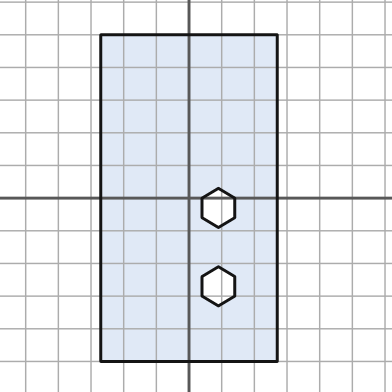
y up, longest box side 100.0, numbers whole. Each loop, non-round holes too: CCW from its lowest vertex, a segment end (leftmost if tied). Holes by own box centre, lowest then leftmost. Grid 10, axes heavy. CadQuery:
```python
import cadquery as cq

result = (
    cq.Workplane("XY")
    .moveTo(-27.0, -50.0)
    .lineTo(27.0, -50.0)
    .lineTo(27.0, 50.0)
    .lineTo(-27.0, 50.0)
    .close()
    .moveTo(9.0, -33.0)
    .lineTo(14.0, -30.0)
    .lineTo(14.0, -24.0)
    .lineTo(9.0, -21.0)
    .lineTo(4.0, -24.0)
    .lineTo(4.0, -30.0)
    .close()
    .moveTo(9.0, -9.0)
    .lineTo(14.0, -6.0)
    .lineTo(14.0, 0.0)
    .lineTo(9.0, 3.0)
    .lineTo(4.0, 0.0)
    .lineTo(4.0, -6.0)
    .close()
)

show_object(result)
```